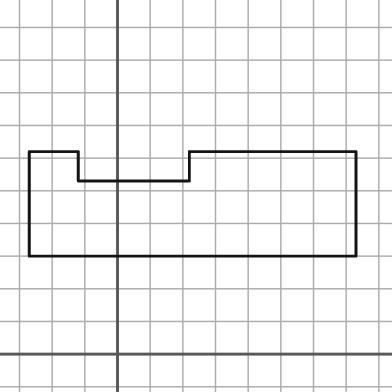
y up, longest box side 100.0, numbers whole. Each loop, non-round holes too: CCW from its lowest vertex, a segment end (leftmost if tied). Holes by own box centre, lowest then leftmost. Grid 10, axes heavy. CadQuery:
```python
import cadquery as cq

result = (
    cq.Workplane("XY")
    .moveTo(-27.0, 30.0)
    .lineTo(73.0, 30.0)
    .lineTo(73.0, 62.0)
    .lineTo(22.0, 62.0)
    .lineTo(22.0, 53.0)
    .lineTo(-12.0, 53.0)
    .lineTo(-12.0, 62.0)
    .lineTo(-27.0, 62.0)
    .close()
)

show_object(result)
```